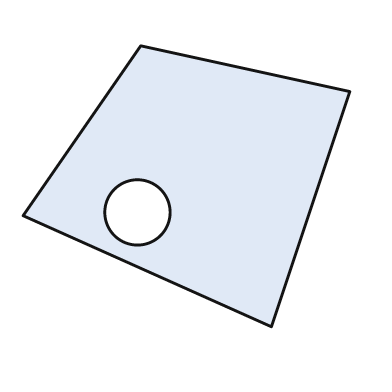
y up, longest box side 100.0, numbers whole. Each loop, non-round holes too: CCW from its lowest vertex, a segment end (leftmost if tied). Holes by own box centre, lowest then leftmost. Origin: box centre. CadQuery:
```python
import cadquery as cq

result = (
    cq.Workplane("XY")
    .moveTo(26.0, -43.0)
    .lineTo(50.0, 29.0)
    .lineTo(-14.0, 43.0)
    .lineTo(-50.0, -9.0)
    .close()
    .moveTo(-15.0, -8.0)
    .circle(10.0)
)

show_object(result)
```